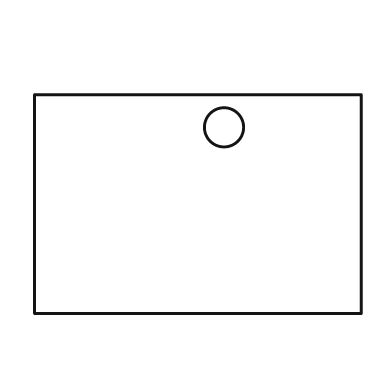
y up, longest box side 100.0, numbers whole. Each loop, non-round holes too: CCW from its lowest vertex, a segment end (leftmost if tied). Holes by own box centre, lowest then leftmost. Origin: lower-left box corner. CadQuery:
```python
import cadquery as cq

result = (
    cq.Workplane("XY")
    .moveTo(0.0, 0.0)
    .lineTo(100.0, 0.0)
    .lineTo(100.0, 67.0)
    .lineTo(0.0, 67.0)
    .close()
    .moveTo(58.0, 57.0)
    .circle(6.0)
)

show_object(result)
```